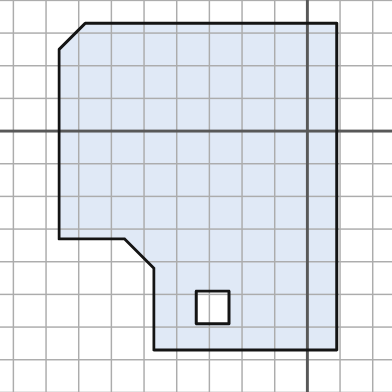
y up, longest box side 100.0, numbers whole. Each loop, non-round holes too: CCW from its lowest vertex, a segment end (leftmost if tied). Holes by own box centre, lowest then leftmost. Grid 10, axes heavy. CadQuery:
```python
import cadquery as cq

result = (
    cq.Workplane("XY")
    .moveTo(-47.0, -67.0)
    .lineTo(9.0, -67.0)
    .lineTo(9.0, 33.0)
    .lineTo(-68.0, 33.0)
    .lineTo(-76.0, 25.0)
    .lineTo(-76.0, -33.0)
    .lineTo(-56.0, -33.0)
    .lineTo(-47.0, -42.0)
    .close()
    .moveTo(-34.0, -59.0)
    .lineTo(-24.0, -59.0)
    .lineTo(-24.0, -49.0)
    .lineTo(-34.0, -49.0)
    .close()
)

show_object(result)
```